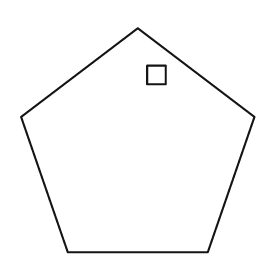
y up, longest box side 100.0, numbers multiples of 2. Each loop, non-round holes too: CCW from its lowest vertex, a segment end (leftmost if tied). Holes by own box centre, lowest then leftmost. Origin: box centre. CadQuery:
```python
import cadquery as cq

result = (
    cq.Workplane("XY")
    .moveTo(-30.0, -48.0)
    .lineTo(30.0, -48.0)
    .lineTo(50.0, 10.0)
    .lineTo(0.0, 48.0)
    .lineTo(-50.0, 10.0)
    .close()
    .moveTo(4.0, 24.0)
    .lineTo(12.0, 24.0)
    .lineTo(12.0, 32.0)
    .lineTo(4.0, 32.0)
    .close()
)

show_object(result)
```